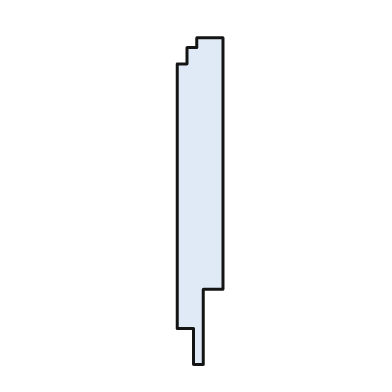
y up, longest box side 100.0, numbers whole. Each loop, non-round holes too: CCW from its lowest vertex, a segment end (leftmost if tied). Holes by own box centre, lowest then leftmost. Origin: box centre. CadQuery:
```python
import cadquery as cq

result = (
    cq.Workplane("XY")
    .moveTo(-2.0, -50.0)
    .lineTo(1.0, -50.0)
    .lineTo(1.0, -27.0)
    .lineTo(7.0, -27.0)
    .lineTo(7.0, 50.0)
    .lineTo(-1.0, 50.0)
    .lineTo(-1.0, 47.0)
    .lineTo(-4.0, 47.0)
    .lineTo(-4.0, 42.0)
    .lineTo(-7.0, 42.0)
    .lineTo(-7.0, -39.0)
    .lineTo(-2.0, -39.0)
    .close()
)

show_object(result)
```